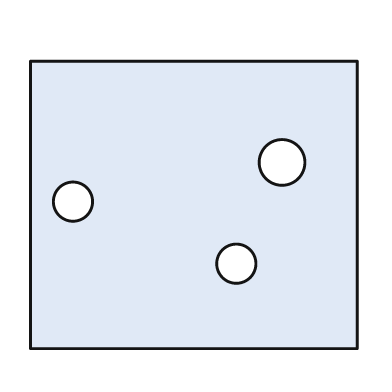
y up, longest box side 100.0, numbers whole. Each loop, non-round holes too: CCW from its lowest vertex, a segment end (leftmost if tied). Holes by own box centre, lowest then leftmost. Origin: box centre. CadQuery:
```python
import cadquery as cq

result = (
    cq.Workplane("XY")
    .moveTo(-50.0, -44.0)
    .lineTo(50.0, -44.0)
    .lineTo(50.0, 44.0)
    .lineTo(-50.0, 44.0)
    .close()
    .moveTo(13.0, -18.0)
    .circle(6.0)
    .moveTo(-37.0, 1.0)
    .circle(6.0)
    .moveTo(27.0, 13.0)
    .circle(7.0)
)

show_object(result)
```